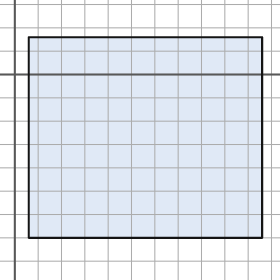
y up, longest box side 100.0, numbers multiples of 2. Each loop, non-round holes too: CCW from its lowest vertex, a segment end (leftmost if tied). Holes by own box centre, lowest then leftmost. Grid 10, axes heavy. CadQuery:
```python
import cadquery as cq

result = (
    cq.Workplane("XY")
    .moveTo(6.0, -70.0)
    .lineTo(106.0, -70.0)
    .lineTo(106.0, 16.0)
    .lineTo(6.0, 16.0)
    .close()
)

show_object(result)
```